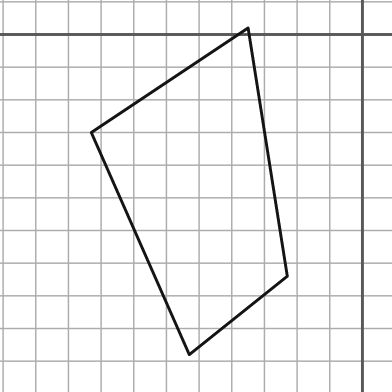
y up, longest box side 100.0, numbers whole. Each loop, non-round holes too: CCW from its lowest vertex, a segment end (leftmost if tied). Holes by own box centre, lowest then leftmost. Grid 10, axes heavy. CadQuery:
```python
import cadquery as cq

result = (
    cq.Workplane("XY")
    .moveTo(-53.0, -98.0)
    .lineTo(-23.0, -74.0)
    .lineTo(-35.0, 2.0)
    .lineTo(-83.0, -30.0)
    .close()
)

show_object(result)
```